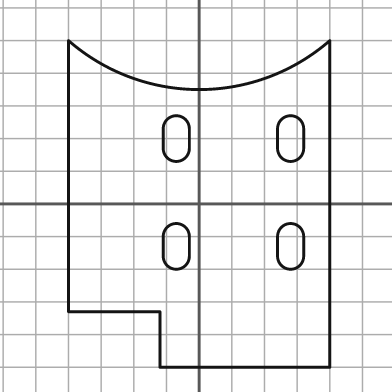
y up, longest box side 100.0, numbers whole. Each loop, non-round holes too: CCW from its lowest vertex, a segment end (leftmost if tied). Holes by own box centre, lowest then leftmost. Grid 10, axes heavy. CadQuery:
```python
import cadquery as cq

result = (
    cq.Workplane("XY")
    .moveTo(-12.0, -50.0)
    .lineTo(40.0, -50.0)
    .lineTo(40.0, 50.0)
    .threePointArc((0.0, 35.0), (-40.0, 50.0))
    .lineTo(-40.0, -33.0)
    .lineTo(-12.0, -33.0)
    .close()
    .moveTo(-11.0, -16.0)
    .threePointArc((-7.0, -20.0), (-3.0, -16.0))
    .lineTo(-3.0, -10.0)
    .threePointArc((-7.0, -6.0), (-11.0, -10.0))
    .close()
    .moveTo(24.0, -16.0)
    .threePointArc((28.0, -20.0), (32.0, -16.0))
    .lineTo(32.0, -10.0)
    .threePointArc((28.0, -6.0), (24.0, -10.0))
    .close()
    .moveTo(-11.0, 17.0)
    .threePointArc((-7.0, 13.0), (-3.0, 17.0))
    .lineTo(-3.0, 23.0)
    .threePointArc((-7.0, 27.0), (-11.0, 23.0))
    .close()
    .moveTo(24.0, 17.0)
    .threePointArc((28.0, 13.0), (32.0, 17.0))
    .lineTo(32.0, 23.0)
    .threePointArc((28.0, 27.0), (24.0, 23.0))
    .close()
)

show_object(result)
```